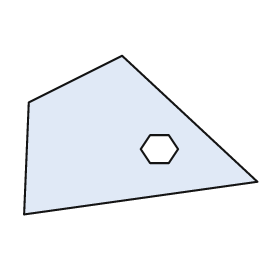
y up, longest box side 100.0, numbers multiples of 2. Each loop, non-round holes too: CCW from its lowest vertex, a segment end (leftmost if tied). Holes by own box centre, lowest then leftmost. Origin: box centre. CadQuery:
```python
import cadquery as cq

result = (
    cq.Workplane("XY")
    .moveTo(-50.0, -34.0)
    .lineTo(50.0, -20.0)
    .lineTo(-8.0, 34.0)
    .lineTo(-48.0, 14.0)
    .close()
    .moveTo(4.0, -12.0)
    .lineTo(12.0, -12.0)
    .lineTo(16.0, -6.0)
    .lineTo(12.0, 0.0)
    .lineTo(4.0, 0.0)
    .lineTo(0.0, -6.0)
    .close()
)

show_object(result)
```